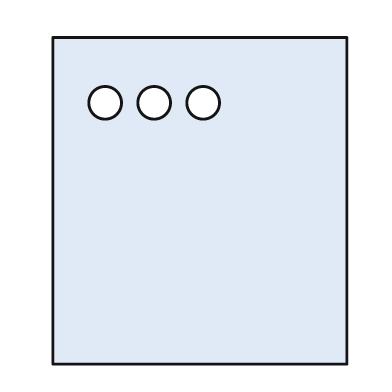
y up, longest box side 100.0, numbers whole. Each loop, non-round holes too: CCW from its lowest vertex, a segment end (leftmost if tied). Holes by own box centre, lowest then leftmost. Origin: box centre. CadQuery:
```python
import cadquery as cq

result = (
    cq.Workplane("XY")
    .moveTo(-45.0, -50.0)
    .lineTo(45.0, -50.0)
    .lineTo(45.0, 50.0)
    .lineTo(-45.0, 50.0)
    .close()
    .moveTo(-29.0, 30.0)
    .circle(5.0)
    .moveTo(-14.0, 30.0)
    .circle(5.0)
    .moveTo(1.0, 30.0)
    .circle(5.0)
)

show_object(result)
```